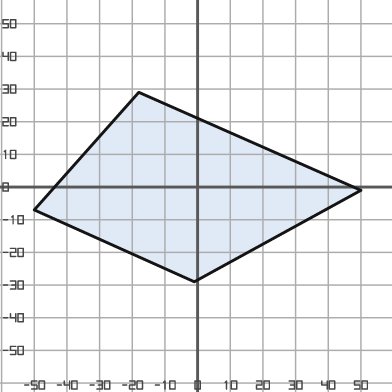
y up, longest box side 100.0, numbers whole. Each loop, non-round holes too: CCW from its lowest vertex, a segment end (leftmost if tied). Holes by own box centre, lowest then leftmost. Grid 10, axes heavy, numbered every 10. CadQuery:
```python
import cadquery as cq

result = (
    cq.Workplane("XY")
    .moveTo(-1.0, -29.0)
    .lineTo(50.0, -1.0)
    .lineTo(-18.0, 29.0)
    .lineTo(-50.0, -7.0)
    .close()
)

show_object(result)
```